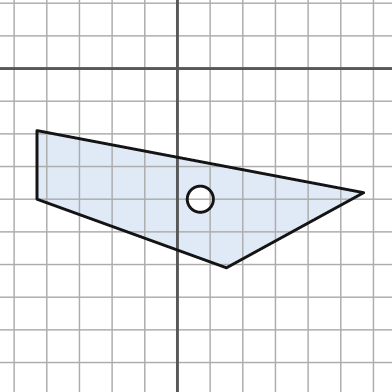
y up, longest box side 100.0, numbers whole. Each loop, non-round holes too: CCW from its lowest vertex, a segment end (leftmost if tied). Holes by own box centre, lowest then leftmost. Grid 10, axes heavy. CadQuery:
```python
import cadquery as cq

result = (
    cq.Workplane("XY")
    .moveTo(15.0, -61.0)
    .lineTo(57.0, -38.0)
    .lineTo(-43.0, -19.0)
    .lineTo(-43.0, -40.0)
    .close()
    .moveTo(7.0, -40.0)
    .circle(4.0)
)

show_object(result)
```